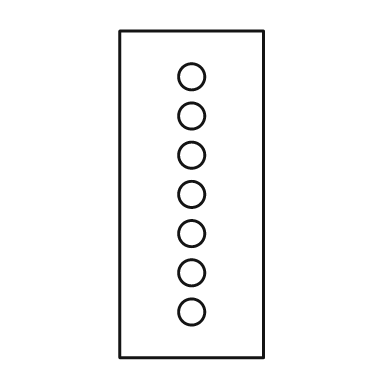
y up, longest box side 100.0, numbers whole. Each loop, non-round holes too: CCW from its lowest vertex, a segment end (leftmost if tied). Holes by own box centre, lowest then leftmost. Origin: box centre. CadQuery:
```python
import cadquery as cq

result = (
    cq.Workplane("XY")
    .moveTo(-22.0, -50.0)
    .lineTo(22.0, -50.0)
    .lineTo(22.0, 50.0)
    .lineTo(-22.0, 50.0)
    .close()
    .moveTo(0.0, -36.0)
    .circle(4.0)
    .moveTo(0.0, -24.0)
    .circle(4.0)
    .moveTo(0.0, -12.0)
    .circle(4.0)
    .moveTo(0.0, 0.0)
    .circle(4.0)
    .moveTo(0.0, 12.0)
    .circle(4.0)
    .moveTo(0.0, 24.0)
    .circle(4.0)
    .moveTo(0.0, 36.0)
    .circle(4.0)
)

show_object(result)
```